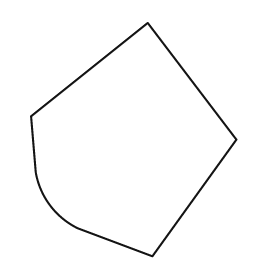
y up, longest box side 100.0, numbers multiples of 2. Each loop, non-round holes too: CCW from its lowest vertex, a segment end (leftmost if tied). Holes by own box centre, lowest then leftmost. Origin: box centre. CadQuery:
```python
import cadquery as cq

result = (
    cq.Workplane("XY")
    .moveTo(8.0, -50.0)
    .lineTo(44.0, 0.0)
    .lineTo(6.0, 50.0)
    .lineTo(-44.0, 10.0)
    .lineTo(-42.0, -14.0)
    .threePointArc((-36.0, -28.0), (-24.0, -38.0))
    .close()
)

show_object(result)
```